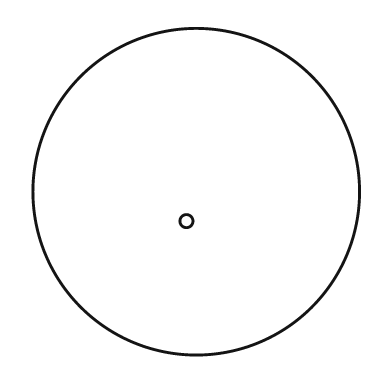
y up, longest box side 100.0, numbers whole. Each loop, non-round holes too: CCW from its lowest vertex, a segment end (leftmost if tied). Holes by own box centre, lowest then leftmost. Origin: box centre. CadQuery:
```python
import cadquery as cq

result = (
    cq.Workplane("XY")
    .moveTo(0.0, 0.0)
    .circle(50.0)
    .moveTo(-3.0, -9.0)
    .circle(2.0)
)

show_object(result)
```